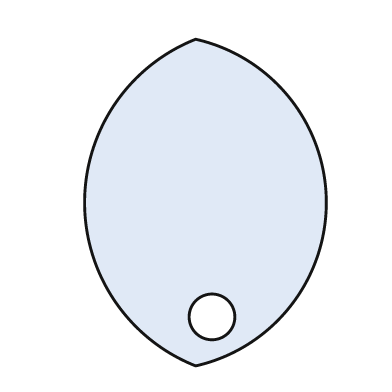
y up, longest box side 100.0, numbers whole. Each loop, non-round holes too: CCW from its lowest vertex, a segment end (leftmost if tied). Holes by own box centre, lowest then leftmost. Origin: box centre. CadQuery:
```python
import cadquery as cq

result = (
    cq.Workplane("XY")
    .moveTo(-3.0, -50.0)
    .threePointArc((37.0, 0.0), (-3.0, 50.0))
    .threePointArc((-37.0, 0.0), (-3.0, -50.0))
    .close()
    .moveTo(2.0, -35.0)
    .circle(7.0)
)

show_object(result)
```